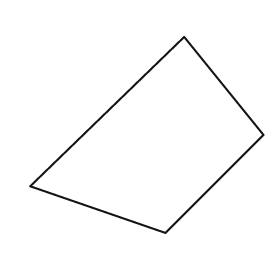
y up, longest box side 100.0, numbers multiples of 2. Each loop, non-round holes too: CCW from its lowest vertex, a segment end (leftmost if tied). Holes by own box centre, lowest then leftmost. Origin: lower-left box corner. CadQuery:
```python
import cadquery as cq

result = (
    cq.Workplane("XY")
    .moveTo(58.0, 0.0)
    .lineTo(100.0, 42.0)
    .lineTo(66.0, 84.0)
    .lineTo(0.0, 20.0)
    .close()
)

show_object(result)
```